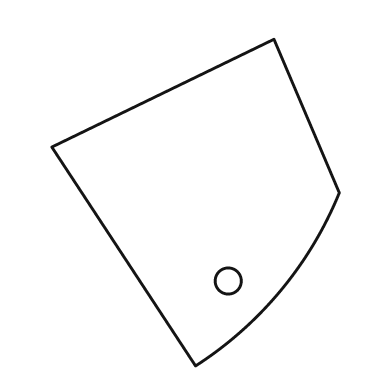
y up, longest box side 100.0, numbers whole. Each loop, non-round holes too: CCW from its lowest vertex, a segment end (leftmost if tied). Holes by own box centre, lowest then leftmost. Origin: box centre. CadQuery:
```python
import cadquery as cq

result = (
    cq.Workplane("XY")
    .moveTo(0.0, -50.0)
    .threePointArc((26.0, -27.0), (44.0, 3.0))
    .lineTo(24.0, 50.0)
    .lineTo(-44.0, 17.0)
    .close()
    .moveTo(10.0, -24.0)
    .circle(4.0)
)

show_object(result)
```